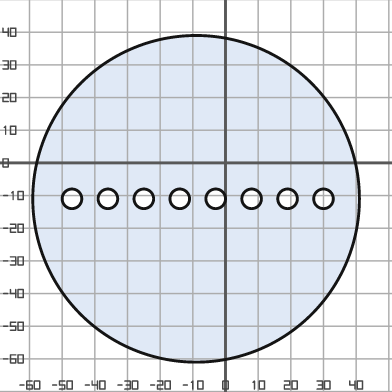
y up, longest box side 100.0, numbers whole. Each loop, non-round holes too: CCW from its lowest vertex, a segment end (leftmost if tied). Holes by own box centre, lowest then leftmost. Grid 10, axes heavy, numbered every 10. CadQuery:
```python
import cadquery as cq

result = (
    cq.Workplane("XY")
    .moveTo(-9.0, -11.0)
    .circle(50.0)
    .moveTo(-47.0, -11.0)
    .circle(3.0)
    .moveTo(-36.0, -11.0)
    .circle(3.0)
    .moveTo(-25.0, -11.0)
    .circle(3.0)
    .moveTo(-14.0, -11.0)
    .circle(3.0)
    .moveTo(-3.0, -11.0)
    .circle(3.0)
    .moveTo(8.0, -11.0)
    .circle(3.0)
    .moveTo(19.0, -11.0)
    .circle(3.0)
    .moveTo(30.0, -11.0)
    .circle(3.0)
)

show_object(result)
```